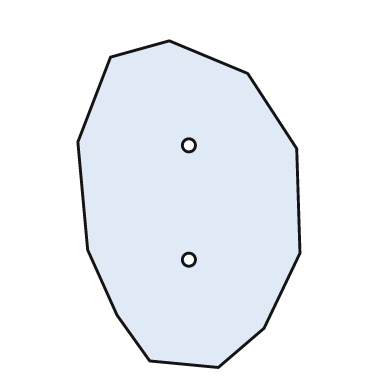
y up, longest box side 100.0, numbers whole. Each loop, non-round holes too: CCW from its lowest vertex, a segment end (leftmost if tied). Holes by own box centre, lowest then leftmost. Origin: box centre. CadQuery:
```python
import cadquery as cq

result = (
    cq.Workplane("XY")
    .moveTo(9.0, -50.0)
    .lineTo(23.0, -38.0)
    .lineTo(34.0, -15.0)
    .lineTo(33.0, 17.0)
    .lineTo(18.0, 40.0)
    .lineTo(-6.0, 50.0)
    .lineTo(-24.0, 45.0)
    .lineTo(-34.0, 19.0)
    .lineTo(-31.0, -14.0)
    .lineTo(-22.0, -34.0)
    .lineTo(-12.0, -48.0)
    .close()
    .moveTo(0.0, -17.0)
    .circle(2.0)
    .moveTo(0.0, 18.0)
    .circle(2.0)
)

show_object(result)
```